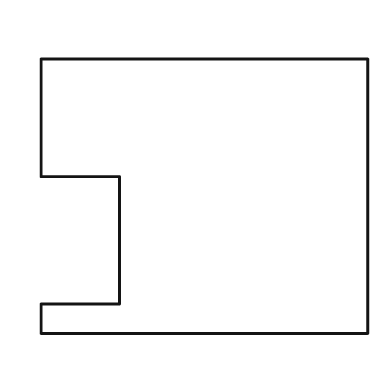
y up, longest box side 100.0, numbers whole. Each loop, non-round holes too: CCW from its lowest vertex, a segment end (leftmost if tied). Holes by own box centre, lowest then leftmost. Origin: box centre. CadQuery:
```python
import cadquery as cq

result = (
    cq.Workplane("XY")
    .moveTo(-50.0, -42.0)
    .lineTo(50.0, -42.0)
    .lineTo(50.0, 42.0)
    .lineTo(-50.0, 42.0)
    .lineTo(-50.0, 6.0)
    .lineTo(-26.0, 6.0)
    .lineTo(-26.0, -33.0)
    .lineTo(-50.0, -33.0)
    .close()
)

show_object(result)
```